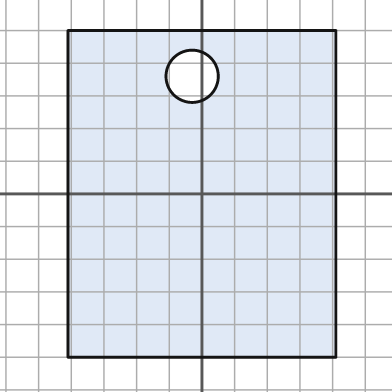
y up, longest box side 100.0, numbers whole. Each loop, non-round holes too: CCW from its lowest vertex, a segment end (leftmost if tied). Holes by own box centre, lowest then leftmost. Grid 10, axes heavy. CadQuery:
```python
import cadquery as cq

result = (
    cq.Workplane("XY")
    .moveTo(-41.0, -50.0)
    .lineTo(41.0, -50.0)
    .lineTo(41.0, 50.0)
    .lineTo(-41.0, 50.0)
    .close()
    .moveTo(-3.0, 36.0)
    .circle(8.0)
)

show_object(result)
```